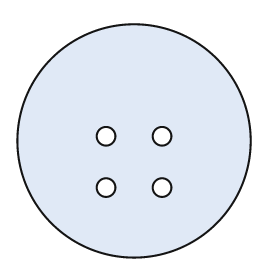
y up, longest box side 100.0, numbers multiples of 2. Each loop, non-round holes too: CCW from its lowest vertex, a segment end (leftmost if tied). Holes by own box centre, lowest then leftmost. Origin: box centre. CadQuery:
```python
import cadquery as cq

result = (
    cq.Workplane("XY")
    .moveTo(0.0, 0.0)
    .circle(50.0)
    .moveTo(-12.0, -20.0)
    .circle(4.0)
    .moveTo(12.0, -20.0)
    .circle(4.0)
    .moveTo(-12.0, 2.0)
    .circle(4.0)
    .moveTo(12.0, 2.0)
    .circle(4.0)
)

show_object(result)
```